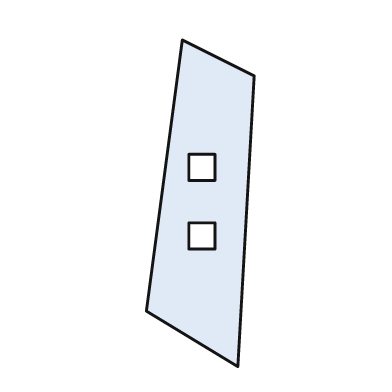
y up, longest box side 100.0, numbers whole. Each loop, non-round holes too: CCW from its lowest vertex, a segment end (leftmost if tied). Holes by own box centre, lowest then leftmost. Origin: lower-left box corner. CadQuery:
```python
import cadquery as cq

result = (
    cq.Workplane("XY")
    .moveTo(28.0, 0.0)
    .lineTo(33.0, 89.0)
    .lineTo(11.0, 100.0)
    .lineTo(0.0, 17.0)
    .close()
    .moveTo(13.0, 36.0)
    .lineTo(21.0, 36.0)
    .lineTo(21.0, 44.0)
    .lineTo(13.0, 44.0)
    .close()
    .moveTo(13.0, 57.0)
    .lineTo(21.0, 57.0)
    .lineTo(21.0, 65.0)
    .lineTo(13.0, 65.0)
    .close()
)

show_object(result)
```